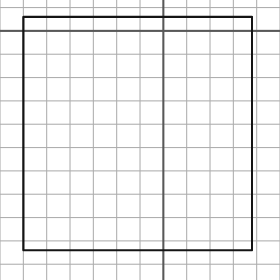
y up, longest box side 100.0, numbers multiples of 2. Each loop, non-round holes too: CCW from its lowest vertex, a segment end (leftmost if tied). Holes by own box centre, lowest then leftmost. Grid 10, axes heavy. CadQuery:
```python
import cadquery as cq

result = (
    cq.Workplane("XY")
    .moveTo(-60.0, -94.0)
    .lineTo(38.0, -94.0)
    .lineTo(38.0, 6.0)
    .lineTo(-60.0, 6.0)
    .close()
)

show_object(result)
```